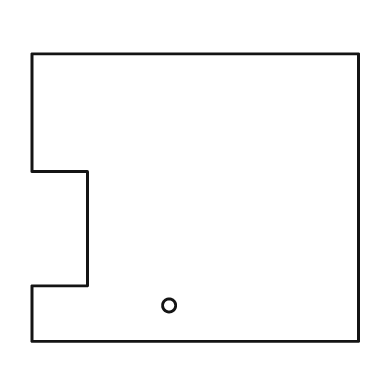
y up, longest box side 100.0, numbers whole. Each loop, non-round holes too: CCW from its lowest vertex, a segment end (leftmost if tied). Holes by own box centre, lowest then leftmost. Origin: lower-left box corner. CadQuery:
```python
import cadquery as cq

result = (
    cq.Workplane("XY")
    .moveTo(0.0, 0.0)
    .lineTo(100.0, 0.0)
    .lineTo(100.0, 88.0)
    .lineTo(0.0, 88.0)
    .lineTo(0.0, 52.0)
    .lineTo(17.0, 52.0)
    .lineTo(17.0, 17.0)
    .lineTo(0.0, 17.0)
    .close()
    .moveTo(42.0, 11.0)
    .circle(2.0)
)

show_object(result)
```